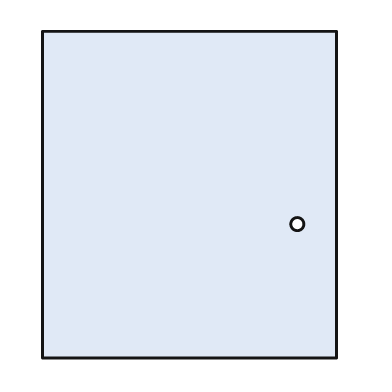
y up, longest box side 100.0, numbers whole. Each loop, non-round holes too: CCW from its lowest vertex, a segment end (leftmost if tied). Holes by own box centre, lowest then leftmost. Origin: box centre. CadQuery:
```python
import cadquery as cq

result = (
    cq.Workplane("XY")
    .moveTo(-45.0, -50.0)
    .lineTo(45.0, -50.0)
    .lineTo(45.0, 50.0)
    .lineTo(-45.0, 50.0)
    .close()
    .moveTo(33.0, -9.0)
    .circle(2.0)
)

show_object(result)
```